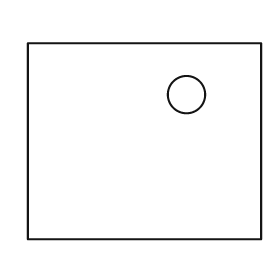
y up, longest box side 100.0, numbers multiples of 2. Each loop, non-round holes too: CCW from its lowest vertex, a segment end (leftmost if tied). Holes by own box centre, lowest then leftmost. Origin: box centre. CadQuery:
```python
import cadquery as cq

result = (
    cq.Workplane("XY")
    .moveTo(-50.0, -42.0)
    .lineTo(50.0, -42.0)
    .lineTo(50.0, 42.0)
    .lineTo(-50.0, 42.0)
    .close()
    .moveTo(18.0, 20.0)
    .circle(8.0)
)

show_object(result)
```